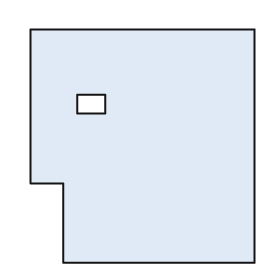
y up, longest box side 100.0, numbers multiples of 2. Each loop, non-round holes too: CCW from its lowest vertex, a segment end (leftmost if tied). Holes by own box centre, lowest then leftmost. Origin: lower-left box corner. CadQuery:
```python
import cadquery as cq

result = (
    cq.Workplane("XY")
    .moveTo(14.0, 0.0)
    .lineTo(96.0, 0.0)
    .lineTo(96.0, 100.0)
    .lineTo(0.0, 100.0)
    .lineTo(0.0, 34.0)
    .lineTo(14.0, 34.0)
    .close()
    .moveTo(20.0, 64.0)
    .lineTo(32.0, 64.0)
    .lineTo(32.0, 72.0)
    .lineTo(20.0, 72.0)
    .close()
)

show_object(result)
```